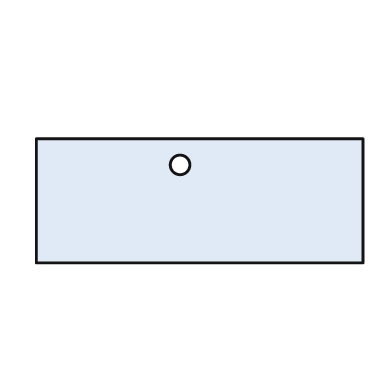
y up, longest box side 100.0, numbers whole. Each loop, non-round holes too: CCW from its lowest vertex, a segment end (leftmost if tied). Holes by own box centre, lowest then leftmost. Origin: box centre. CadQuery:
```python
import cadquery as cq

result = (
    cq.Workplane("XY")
    .moveTo(-50.0, -19.0)
    .lineTo(50.0, -19.0)
    .lineTo(50.0, 19.0)
    .lineTo(-50.0, 19.0)
    .close()
    .moveTo(-6.0, 11.0)
    .circle(3.0)
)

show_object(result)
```